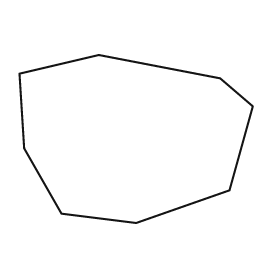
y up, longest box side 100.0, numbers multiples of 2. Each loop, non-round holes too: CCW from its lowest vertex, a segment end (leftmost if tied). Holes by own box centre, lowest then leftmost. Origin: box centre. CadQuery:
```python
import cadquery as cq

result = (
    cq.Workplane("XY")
    .moveTo(0.0, -36.0)
    .lineTo(40.0, -22.0)
    .lineTo(50.0, 14.0)
    .lineTo(36.0, 26.0)
    .lineTo(-16.0, 36.0)
    .lineTo(-50.0, 28.0)
    .lineTo(-48.0, -4.0)
    .lineTo(-32.0, -32.0)
    .close()
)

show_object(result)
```